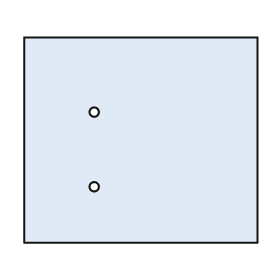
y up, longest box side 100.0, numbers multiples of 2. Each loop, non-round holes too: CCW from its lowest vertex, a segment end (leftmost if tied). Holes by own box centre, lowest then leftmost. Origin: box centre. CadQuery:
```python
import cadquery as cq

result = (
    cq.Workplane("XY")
    .moveTo(-50.0, -44.0)
    .lineTo(50.0, -44.0)
    .lineTo(50.0, 44.0)
    .lineTo(-50.0, 44.0)
    .close()
    .moveTo(-20.0, -20.0)
    .circle(2.0)
    .moveTo(-20.0, 12.0)
    .circle(2.0)
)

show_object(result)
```